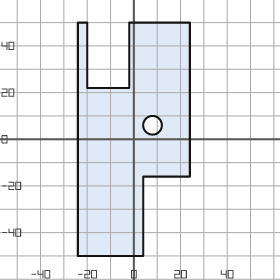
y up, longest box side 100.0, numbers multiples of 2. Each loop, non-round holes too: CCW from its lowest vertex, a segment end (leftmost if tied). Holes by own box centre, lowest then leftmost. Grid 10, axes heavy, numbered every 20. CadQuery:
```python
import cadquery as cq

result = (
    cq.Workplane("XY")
    .moveTo(-24.0, -50.0)
    .lineTo(4.0, -50.0)
    .lineTo(4.0, -16.0)
    .lineTo(24.0, -16.0)
    .lineTo(24.0, 50.0)
    .lineTo(-2.0, 50.0)
    .lineTo(-2.0, 22.0)
    .lineTo(-20.0, 22.0)
    .lineTo(-20.0, 50.0)
    .lineTo(-24.0, 50.0)
    .close()
    .moveTo(8.0, 6.0)
    .circle(4.0)
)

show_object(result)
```